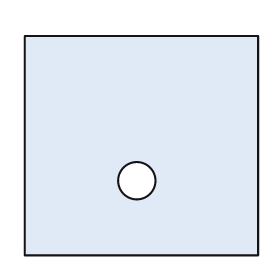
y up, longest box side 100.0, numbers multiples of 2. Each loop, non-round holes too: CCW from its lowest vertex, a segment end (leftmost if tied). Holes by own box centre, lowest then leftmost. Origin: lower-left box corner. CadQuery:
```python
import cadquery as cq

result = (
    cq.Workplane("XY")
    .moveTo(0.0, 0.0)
    .lineTo(100.0, 0.0)
    .lineTo(100.0, 94.0)
    .lineTo(0.0, 94.0)
    .close()
    .moveTo(48.0, 32.0)
    .circle(8.0)
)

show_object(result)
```